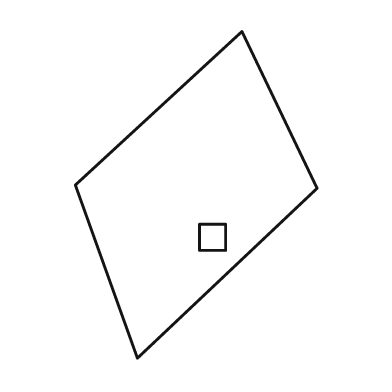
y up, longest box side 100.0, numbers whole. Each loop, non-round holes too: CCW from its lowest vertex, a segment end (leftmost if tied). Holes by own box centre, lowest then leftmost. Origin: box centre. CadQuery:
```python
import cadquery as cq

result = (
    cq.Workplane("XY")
    .moveTo(-18.0, -50.0)
    .lineTo(37.0, 2.0)
    .lineTo(14.0, 50.0)
    .lineTo(-37.0, 3.0)
    .close()
    .moveTo(1.0, -17.0)
    .lineTo(9.0, -17.0)
    .lineTo(9.0, -9.0)
    .lineTo(1.0, -9.0)
    .close()
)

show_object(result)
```